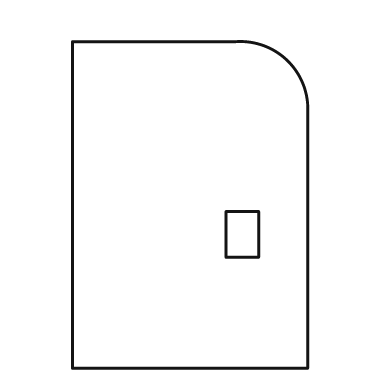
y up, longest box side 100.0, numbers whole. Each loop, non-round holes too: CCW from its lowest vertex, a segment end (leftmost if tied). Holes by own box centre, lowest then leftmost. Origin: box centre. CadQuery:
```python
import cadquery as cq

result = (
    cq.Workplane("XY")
    .moveTo(-36.0, -50.0)
    .lineTo(36.0, -50.0)
    .lineTo(36.0, 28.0)
    .threePointArc((30.0, 44.0), (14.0, 50.0))
    .lineTo(-36.0, 50.0)
    .close()
    .moveTo(11.0, -16.0)
    .lineTo(21.0, -16.0)
    .lineTo(21.0, -2.0)
    .lineTo(11.0, -2.0)
    .close()
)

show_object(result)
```